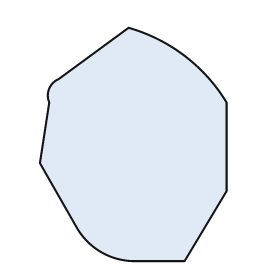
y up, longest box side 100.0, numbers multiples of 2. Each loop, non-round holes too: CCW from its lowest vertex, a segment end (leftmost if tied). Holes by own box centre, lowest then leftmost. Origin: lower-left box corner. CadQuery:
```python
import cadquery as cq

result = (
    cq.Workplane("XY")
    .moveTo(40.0, 0.0)
    .lineTo(62.0, 0.0)
    .lineTo(80.0, 30.0)
    .lineTo(80.0, 68.0)
    .threePointArc((62.0, 88.0), (38.0, 100.0))
    .lineTo(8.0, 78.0)
    .threePointArc((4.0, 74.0), (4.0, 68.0))
    .lineTo(0.0, 42.0)
    .lineTo(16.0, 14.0)
    .threePointArc((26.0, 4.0), (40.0, 0.0))
    .close()
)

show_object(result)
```